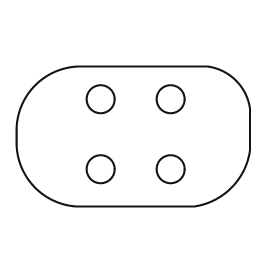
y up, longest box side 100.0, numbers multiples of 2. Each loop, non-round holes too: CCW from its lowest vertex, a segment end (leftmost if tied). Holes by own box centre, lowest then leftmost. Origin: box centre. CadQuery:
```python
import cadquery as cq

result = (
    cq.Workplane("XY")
    .moveTo(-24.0, -30.0)
    .lineTo(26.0, -30.0)
    .threePointArc((42.0, -22.0), (50.0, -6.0))
    .lineTo(50.0, 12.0)
    .threePointArc((44.0, 24.0), (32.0, 30.0))
    .lineTo(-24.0, 30.0)
    .threePointArc((-42.0, 22.0), (-50.0, 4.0))
    .lineTo(-50.0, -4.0)
    .threePointArc((-42.0, -22.0), (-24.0, -30.0))
    .close()
    .moveTo(-14.0, -14.0)
    .circle(6.0)
    .moveTo(16.0, -14.0)
    .circle(6.0)
    .moveTo(-14.0, 16.0)
    .circle(6.0)
    .moveTo(16.0, 16.0)
    .circle(6.0)
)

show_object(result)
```